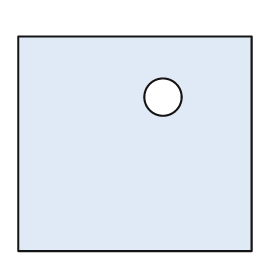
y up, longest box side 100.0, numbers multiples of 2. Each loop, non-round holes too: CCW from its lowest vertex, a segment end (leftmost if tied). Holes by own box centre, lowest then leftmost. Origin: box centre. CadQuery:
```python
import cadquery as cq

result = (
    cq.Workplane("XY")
    .moveTo(-50.0, -46.0)
    .lineTo(50.0, -46.0)
    .lineTo(50.0, 46.0)
    .lineTo(-50.0, 46.0)
    .close()
    .moveTo(12.0, 20.0)
    .circle(8.0)
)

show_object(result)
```